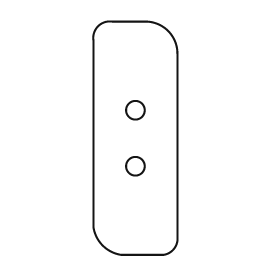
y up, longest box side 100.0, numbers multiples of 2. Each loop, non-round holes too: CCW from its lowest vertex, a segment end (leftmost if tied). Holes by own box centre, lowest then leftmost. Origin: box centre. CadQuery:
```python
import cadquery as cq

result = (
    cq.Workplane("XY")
    .moveTo(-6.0, -50.0)
    .lineTo(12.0, -50.0)
    .threePointArc((16.0, -48.0), (18.0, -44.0))
    .lineTo(18.0, 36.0)
    .threePointArc((14.0, 46.0), (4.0, 50.0))
    .lineTo(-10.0, 50.0)
    .threePointArc((-16.0, 48.0), (-18.0, 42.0))
    .lineTo(-18.0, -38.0)
    .threePointArc((-14.0, -46.0), (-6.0, -50.0))
    .close()
    .moveTo(0.0, -12.0)
    .circle(4.0)
    .moveTo(0.0, 12.0)
    .circle(4.0)
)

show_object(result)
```